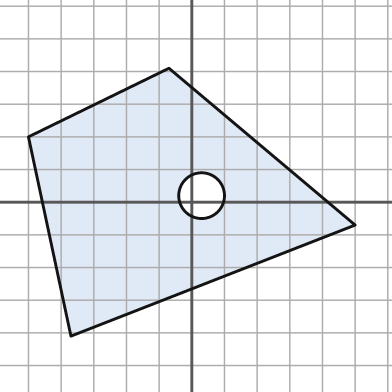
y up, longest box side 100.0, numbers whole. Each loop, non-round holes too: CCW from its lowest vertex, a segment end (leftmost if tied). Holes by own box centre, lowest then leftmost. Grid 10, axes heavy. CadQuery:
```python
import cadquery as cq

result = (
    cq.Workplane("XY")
    .moveTo(-37.0, -41.0)
    .lineTo(50.0, -7.0)
    .lineTo(-7.0, 41.0)
    .lineTo(-50.0, 20.0)
    .close()
    .moveTo(3.0, 2.0)
    .circle(7.0)
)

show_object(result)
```